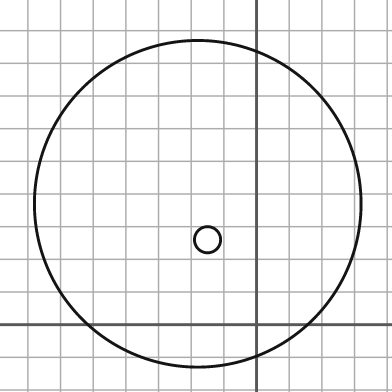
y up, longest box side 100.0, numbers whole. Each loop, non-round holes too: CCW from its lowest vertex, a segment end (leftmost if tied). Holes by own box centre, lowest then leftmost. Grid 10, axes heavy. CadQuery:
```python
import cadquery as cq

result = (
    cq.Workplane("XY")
    .moveTo(-18.0, 37.0)
    .circle(50.0)
    .moveTo(-15.0, 26.0)
    .circle(4.0)
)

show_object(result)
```